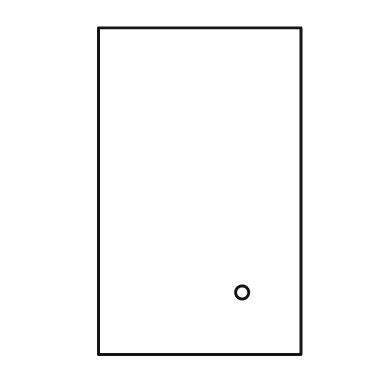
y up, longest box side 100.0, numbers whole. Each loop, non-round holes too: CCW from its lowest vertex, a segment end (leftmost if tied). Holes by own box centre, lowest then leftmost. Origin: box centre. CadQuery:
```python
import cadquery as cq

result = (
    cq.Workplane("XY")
    .moveTo(-31.0, -50.0)
    .lineTo(31.0, -50.0)
    .lineTo(31.0, 50.0)
    .lineTo(-31.0, 50.0)
    .close()
    .moveTo(13.0, -31.0)
    .circle(2.0)
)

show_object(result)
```